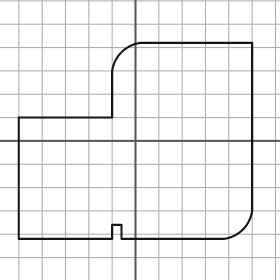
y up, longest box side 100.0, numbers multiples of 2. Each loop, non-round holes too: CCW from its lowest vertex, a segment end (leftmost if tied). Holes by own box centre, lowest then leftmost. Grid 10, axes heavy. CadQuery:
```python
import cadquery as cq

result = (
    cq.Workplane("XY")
    .moveTo(-50.0, -42.0)
    .lineTo(-10.0, -42.0)
    .lineTo(-10.0, -36.0)
    .lineTo(-6.0, -36.0)
    .lineTo(-6.0, -42.0)
    .lineTo(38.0, -42.0)
    .threePointArc((46.0, -38.0), (50.0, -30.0))
    .lineTo(50.0, 42.0)
    .lineTo(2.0, 42.0)
    .threePointArc((-6.0, 38.0), (-10.0, 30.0))
    .lineTo(-10.0, 10.0)
    .lineTo(-50.0, 10.0)
    .close()
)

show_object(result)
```